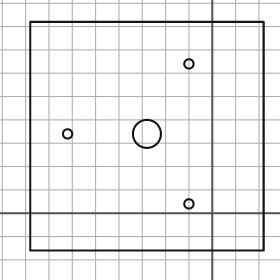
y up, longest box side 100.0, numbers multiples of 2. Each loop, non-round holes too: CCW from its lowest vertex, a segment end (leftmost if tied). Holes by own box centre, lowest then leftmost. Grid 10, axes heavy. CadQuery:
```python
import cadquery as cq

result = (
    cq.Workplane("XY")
    .moveTo(-78.0, -16.0)
    .lineTo(22.0, -16.0)
    .lineTo(22.0, 82.0)
    .lineTo(-78.0, 82.0)
    .close()
    .moveTo(-10.0, 4.0)
    .circle(2.0)
    .moveTo(-62.0, 34.0)
    .circle(2.0)
    .moveTo(-28.0, 34.0)
    .circle(6.0)
    .moveTo(-10.0, 64.0)
    .circle(2.0)
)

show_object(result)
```